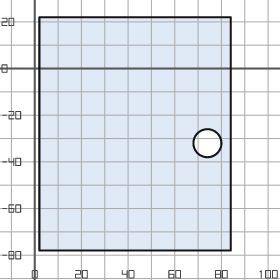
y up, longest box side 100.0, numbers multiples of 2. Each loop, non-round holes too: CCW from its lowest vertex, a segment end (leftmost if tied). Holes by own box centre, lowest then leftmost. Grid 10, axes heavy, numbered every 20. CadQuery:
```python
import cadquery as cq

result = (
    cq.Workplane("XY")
    .moveTo(2.0, -78.0)
    .lineTo(84.0, -78.0)
    .lineTo(84.0, 22.0)
    .lineTo(2.0, 22.0)
    .close()
    .moveTo(74.0, -32.0)
    .circle(6.0)
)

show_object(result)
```